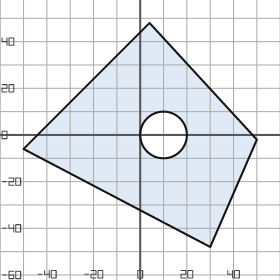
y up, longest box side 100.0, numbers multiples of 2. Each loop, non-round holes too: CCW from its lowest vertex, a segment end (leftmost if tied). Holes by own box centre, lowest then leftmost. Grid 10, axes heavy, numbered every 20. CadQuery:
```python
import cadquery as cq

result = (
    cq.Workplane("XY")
    .moveTo(30.0, -48.0)
    .lineTo(50.0, -2.0)
    .lineTo(4.0, 48.0)
    .lineTo(-50.0, -6.0)
    .close()
    .moveTo(10.0, 0.0)
    .circle(10.0)
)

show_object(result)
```